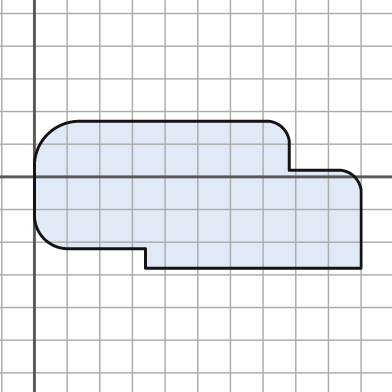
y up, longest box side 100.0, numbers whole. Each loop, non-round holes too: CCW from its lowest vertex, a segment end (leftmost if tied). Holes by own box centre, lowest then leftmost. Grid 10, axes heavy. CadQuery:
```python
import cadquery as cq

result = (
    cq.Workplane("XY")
    .moveTo(34.0, -28.0)
    .lineTo(100.0, -28.0)
    .lineTo(100.0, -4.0)
    .threePointArc((98.0, 0.0), (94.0, 2.0))
    .lineTo(78.0, 2.0)
    .lineTo(78.0, 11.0)
    .threePointArc((76.0, 15.0), (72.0, 17.0))
    .lineTo(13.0, 17.0)
    .threePointArc((4.0, 13.0), (0.0, 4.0))
    .lineTo(0.0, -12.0)
    .threePointArc((3.0, -19.0), (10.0, -22.0))
    .lineTo(34.0, -22.0)
    .close()
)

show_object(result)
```